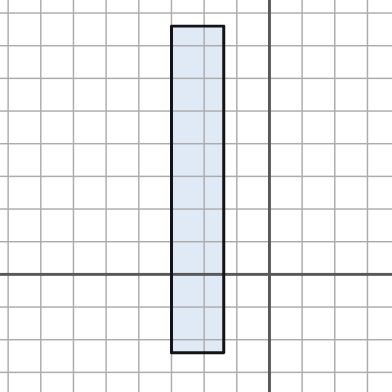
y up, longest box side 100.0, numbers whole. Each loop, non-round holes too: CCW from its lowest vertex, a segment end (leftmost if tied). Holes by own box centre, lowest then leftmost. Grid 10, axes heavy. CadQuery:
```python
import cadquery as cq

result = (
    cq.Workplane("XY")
    .moveTo(-30.0, -24.0)
    .lineTo(-14.0, -24.0)
    .lineTo(-14.0, 76.0)
    .lineTo(-30.0, 76.0)
    .close()
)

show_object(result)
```